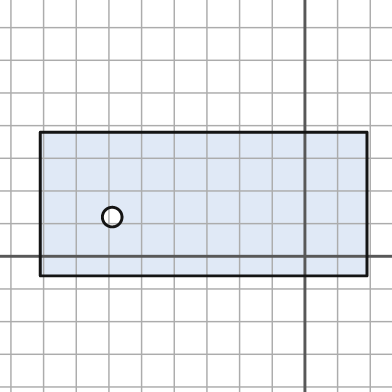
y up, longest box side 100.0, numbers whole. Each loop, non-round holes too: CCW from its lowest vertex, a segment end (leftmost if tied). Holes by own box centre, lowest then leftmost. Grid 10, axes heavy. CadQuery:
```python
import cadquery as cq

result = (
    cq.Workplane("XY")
    .moveTo(-81.0, -6.0)
    .lineTo(19.0, -6.0)
    .lineTo(19.0, 38.0)
    .lineTo(-81.0, 38.0)
    .close()
    .moveTo(-59.0, 12.0)
    .circle(3.0)
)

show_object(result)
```